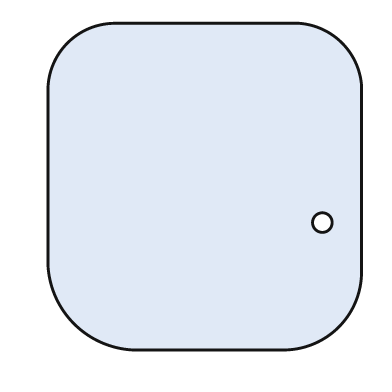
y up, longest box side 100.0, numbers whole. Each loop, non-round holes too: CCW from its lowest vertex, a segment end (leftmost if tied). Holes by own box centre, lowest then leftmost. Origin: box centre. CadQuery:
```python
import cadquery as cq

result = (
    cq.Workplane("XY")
    .moveTo(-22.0, -50.0)
    .lineTo(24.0, -50.0)
    .threePointArc((41.0, -43.0), (48.0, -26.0))
    .lineTo(48.0, 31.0)
    .threePointArc((42.0, 44.0), (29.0, 50.0))
    .lineTo(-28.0, 50.0)
    .threePointArc((-42.0, 44.0), (-48.0, 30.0))
    .lineTo(-48.0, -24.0)
    .threePointArc((-40.0, -42.0), (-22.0, -50.0))
    .close()
    .moveTo(36.0, -11.0)
    .circle(3.0)
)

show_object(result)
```